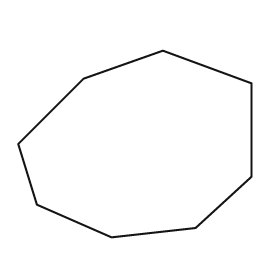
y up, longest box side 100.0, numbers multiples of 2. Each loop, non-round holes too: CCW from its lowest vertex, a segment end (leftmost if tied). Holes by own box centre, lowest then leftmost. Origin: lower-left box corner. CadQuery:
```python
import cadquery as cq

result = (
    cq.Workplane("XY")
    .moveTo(40.0, 0.0)
    .lineTo(76.0, 4.0)
    .lineTo(100.0, 26.0)
    .lineTo(100.0, 66.0)
    .lineTo(62.0, 80.0)
    .lineTo(28.0, 68.0)
    .lineTo(0.0, 40.0)
    .lineTo(8.0, 14.0)
    .close()
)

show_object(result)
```